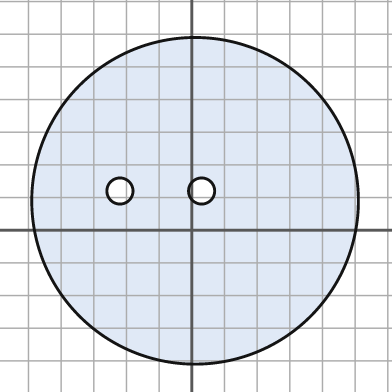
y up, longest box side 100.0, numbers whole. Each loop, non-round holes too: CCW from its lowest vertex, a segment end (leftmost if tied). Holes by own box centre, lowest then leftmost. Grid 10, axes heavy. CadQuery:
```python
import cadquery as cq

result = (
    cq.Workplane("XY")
    .moveTo(1.0, 9.0)
    .circle(50.0)
    .moveTo(-22.0, 12.0)
    .circle(4.0)
    .moveTo(3.0, 12.0)
    .circle(4.0)
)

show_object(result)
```